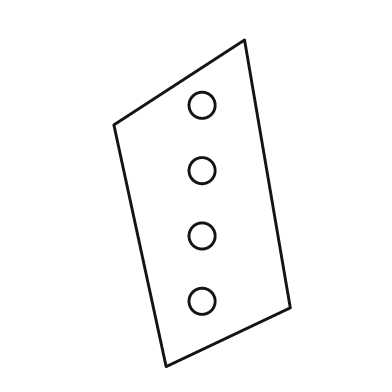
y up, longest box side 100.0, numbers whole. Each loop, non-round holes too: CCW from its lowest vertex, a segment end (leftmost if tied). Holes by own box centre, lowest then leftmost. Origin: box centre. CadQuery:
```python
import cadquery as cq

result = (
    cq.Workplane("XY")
    .moveTo(-11.0, -50.0)
    .lineTo(27.0, -32.0)
    .lineTo(13.0, 50.0)
    .lineTo(-27.0, 24.0)
    .close()
    .moveTo(0.0, -30.0)
    .circle(4.0)
    .moveTo(0.0, -10.0)
    .circle(4.0)
    .moveTo(0.0, 10.0)
    .circle(4.0)
    .moveTo(0.0, 30.0)
    .circle(4.0)
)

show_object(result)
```